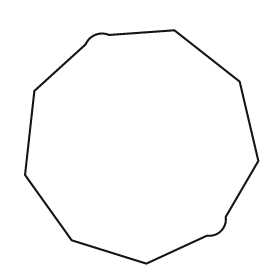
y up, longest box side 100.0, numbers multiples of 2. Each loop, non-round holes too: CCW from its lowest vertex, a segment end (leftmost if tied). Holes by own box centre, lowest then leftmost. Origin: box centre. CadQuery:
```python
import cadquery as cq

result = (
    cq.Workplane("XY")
    .moveTo(2.0, -50.0)
    .lineTo(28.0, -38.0)
    .threePointArc((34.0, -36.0), (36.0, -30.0))
    .lineTo(50.0, -6.0)
    .lineTo(42.0, 28.0)
    .lineTo(14.0, 50.0)
    .lineTo(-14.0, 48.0)
    .threePointArc((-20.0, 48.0), (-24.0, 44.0))
    .lineTo(-46.0, 24.0)
    .lineTo(-50.0, -12.0)
    .lineTo(-30.0, -40.0)
    .close()
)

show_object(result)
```